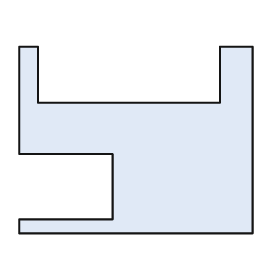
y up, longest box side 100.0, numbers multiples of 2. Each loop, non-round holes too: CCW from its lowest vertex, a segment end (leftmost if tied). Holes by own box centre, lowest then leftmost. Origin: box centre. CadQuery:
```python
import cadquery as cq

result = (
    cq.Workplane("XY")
    .moveTo(-50.0, -40.0)
    .lineTo(50.0, -40.0)
    .lineTo(50.0, 40.0)
    .lineTo(36.0, 40.0)
    .lineTo(36.0, 16.0)
    .lineTo(-42.0, 16.0)
    .lineTo(-42.0, 40.0)
    .lineTo(-50.0, 40.0)
    .lineTo(-50.0, -6.0)
    .lineTo(-10.0, -6.0)
    .lineTo(-10.0, -34.0)
    .lineTo(-50.0, -34.0)
    .close()
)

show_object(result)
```